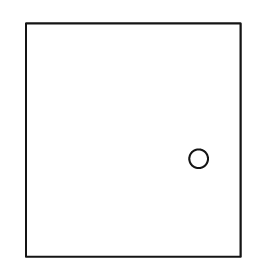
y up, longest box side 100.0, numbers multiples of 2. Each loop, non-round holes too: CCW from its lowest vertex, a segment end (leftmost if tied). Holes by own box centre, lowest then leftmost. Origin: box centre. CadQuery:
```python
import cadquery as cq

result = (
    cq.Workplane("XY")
    .moveTo(-46.0, -50.0)
    .lineTo(46.0, -50.0)
    .lineTo(46.0, 50.0)
    .lineTo(-46.0, 50.0)
    .close()
    .moveTo(28.0, -8.0)
    .circle(4.0)
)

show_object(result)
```